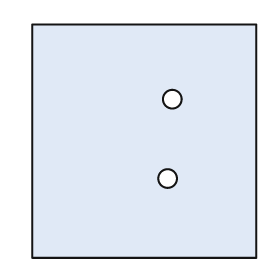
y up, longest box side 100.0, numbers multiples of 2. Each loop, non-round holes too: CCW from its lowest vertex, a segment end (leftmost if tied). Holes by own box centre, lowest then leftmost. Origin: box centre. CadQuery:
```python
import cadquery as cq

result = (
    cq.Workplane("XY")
    .moveTo(-48.0, -50.0)
    .lineTo(48.0, -50.0)
    .lineTo(48.0, 50.0)
    .lineTo(-48.0, 50.0)
    .close()
    .moveTo(10.0, -16.0)
    .circle(4.0)
    .moveTo(12.0, 18.0)
    .circle(4.0)
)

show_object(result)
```